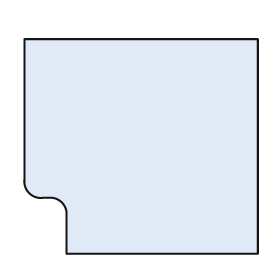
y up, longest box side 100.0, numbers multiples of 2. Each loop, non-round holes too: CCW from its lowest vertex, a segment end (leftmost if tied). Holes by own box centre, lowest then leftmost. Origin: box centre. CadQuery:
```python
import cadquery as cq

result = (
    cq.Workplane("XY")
    .moveTo(-32.0, -46.0)
    .lineTo(50.0, -46.0)
    .lineTo(50.0, 46.0)
    .lineTo(-50.0, 46.0)
    .lineTo(-50.0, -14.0)
    .threePointArc((-48.0, -20.0), (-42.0, -22.0))
    .lineTo(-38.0, -22.0)
    .threePointArc((-34.0, -24.0), (-32.0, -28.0))
    .close()
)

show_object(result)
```